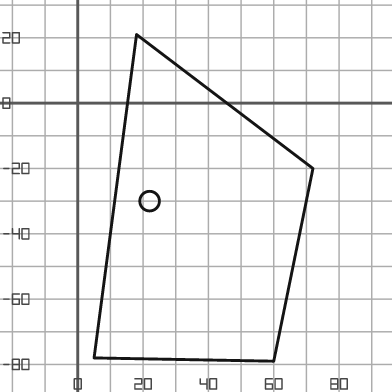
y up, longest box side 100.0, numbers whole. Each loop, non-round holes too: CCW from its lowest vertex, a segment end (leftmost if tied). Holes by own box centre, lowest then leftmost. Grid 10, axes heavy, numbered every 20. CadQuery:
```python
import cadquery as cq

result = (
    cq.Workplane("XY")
    .moveTo(60.0, -79.0)
    .lineTo(72.0, -20.0)
    .lineTo(18.0, 21.0)
    .lineTo(5.0, -78.0)
    .close()
    .moveTo(22.0, -30.0)
    .circle(3.0)
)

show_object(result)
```